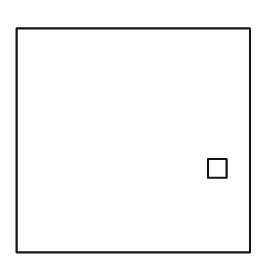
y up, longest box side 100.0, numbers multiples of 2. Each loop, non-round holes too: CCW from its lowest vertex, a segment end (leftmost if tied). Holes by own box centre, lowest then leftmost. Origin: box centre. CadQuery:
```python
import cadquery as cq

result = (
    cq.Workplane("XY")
    .moveTo(-50.0, -48.0)
    .lineTo(50.0, -48.0)
    .lineTo(50.0, 48.0)
    .lineTo(-50.0, 48.0)
    .close()
    .moveTo(32.0, -16.0)
    .lineTo(40.0, -16.0)
    .lineTo(40.0, -8.0)
    .lineTo(32.0, -8.0)
    .close()
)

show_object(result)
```